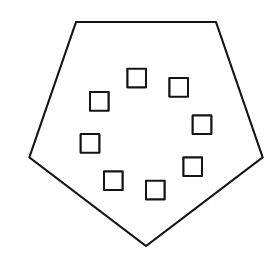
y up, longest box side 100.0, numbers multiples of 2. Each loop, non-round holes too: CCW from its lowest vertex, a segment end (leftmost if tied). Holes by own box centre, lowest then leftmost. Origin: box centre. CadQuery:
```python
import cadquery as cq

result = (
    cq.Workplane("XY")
    .moveTo(0.0, -48.0)
    .lineTo(50.0, -10.0)
    .lineTo(30.0, 48.0)
    .lineTo(-30.0, 48.0)
    .lineTo(-50.0, -10.0)
    .close()
    .moveTo(0.0, -28.0)
    .lineTo(8.0, -28.0)
    .lineTo(8.0, -20.0)
    .lineTo(0.0, -20.0)
    .close()
    .moveTo(-18.0, -24.0)
    .lineTo(-10.0, -24.0)
    .lineTo(-10.0, -16.0)
    .lineTo(-18.0, -16.0)
    .close()
    .moveTo(16.0, -18.0)
    .lineTo(24.0, -18.0)
    .lineTo(24.0, -10.0)
    .lineTo(16.0, -10.0)
    .close()
    .moveTo(-28.0, -8.0)
    .lineTo(-20.0, -8.0)
    .lineTo(-20.0, 0.0)
    .lineTo(-28.0, 0.0)
    .close()
    .moveTo(20.0, 0.0)
    .lineTo(28.0, 0.0)
    .lineTo(28.0, 8.0)
    .lineTo(20.0, 8.0)
    .close()
    .moveTo(-24.0, 10.0)
    .lineTo(-16.0, 10.0)
    .lineTo(-16.0, 18.0)
    .lineTo(-24.0, 18.0)
    .close()
    .moveTo(10.0, 16.0)
    .lineTo(18.0, 16.0)
    .lineTo(18.0, 24.0)
    .lineTo(10.0, 24.0)
    .close()
    .moveTo(-8.0, 20.0)
    .lineTo(0.0, 20.0)
    .lineTo(0.0, 28.0)
    .lineTo(-8.0, 28.0)
    .close()
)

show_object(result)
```